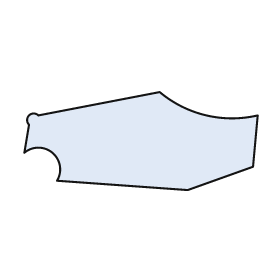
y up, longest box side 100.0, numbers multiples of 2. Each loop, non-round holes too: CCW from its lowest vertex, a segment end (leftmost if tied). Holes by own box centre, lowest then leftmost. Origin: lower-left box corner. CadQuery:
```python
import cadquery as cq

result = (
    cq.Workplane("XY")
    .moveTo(70.0, 0.0)
    .lineTo(98.0, 10.0)
    .lineTo(100.0, 32.0)
    .threePointArc((78.0, 32.0), (58.0, 42.0))
    .lineTo(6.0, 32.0)
    .threePointArc((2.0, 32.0), (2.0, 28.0))
    .lineTo(0.0, 16.0)
    .threePointArc((12.0, 16.0), (14.0, 4.0))
    .close()
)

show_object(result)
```